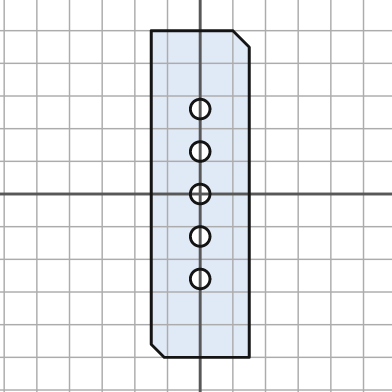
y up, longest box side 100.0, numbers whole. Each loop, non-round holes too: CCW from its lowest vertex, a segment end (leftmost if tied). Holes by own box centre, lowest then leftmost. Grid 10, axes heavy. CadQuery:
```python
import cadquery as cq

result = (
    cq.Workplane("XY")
    .moveTo(-11.0, -50.0)
    .lineTo(15.0, -50.0)
    .lineTo(15.0, 45.0)
    .lineTo(10.0, 50.0)
    .lineTo(-15.0, 50.0)
    .lineTo(-15.0, -46.0)
    .close()
    .moveTo(0.0, -26.0)
    .circle(3.0)
    .moveTo(0.0, -13.0)
    .circle(3.0)
    .moveTo(0.0, 0.0)
    .circle(3.0)
    .moveTo(0.0, 13.0)
    .circle(3.0)
    .moveTo(0.0, 26.0)
    .circle(3.0)
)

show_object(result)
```